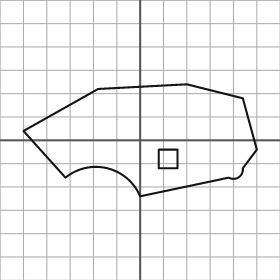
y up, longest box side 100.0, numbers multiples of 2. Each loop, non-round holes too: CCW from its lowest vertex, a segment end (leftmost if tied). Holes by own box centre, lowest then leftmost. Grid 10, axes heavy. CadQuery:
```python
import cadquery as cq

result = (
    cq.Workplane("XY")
    .moveTo(0.0, -24.0)
    .lineTo(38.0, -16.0)
    .threePointArc((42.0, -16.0), (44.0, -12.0))
    .lineTo(50.0, -4.0)
    .lineTo(44.0, 18.0)
    .lineTo(20.0, 24.0)
    .lineTo(-18.0, 22.0)
    .lineTo(-50.0, 4.0)
    .lineTo(-32.0, -16.0)
    .threePointArc((-14.0, -12.0), (0.0, -24.0))
    .close()
    .moveTo(8.0, -12.0)
    .lineTo(16.0, -12.0)
    .lineTo(16.0, -4.0)
    .lineTo(8.0, -4.0)
    .close()
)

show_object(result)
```